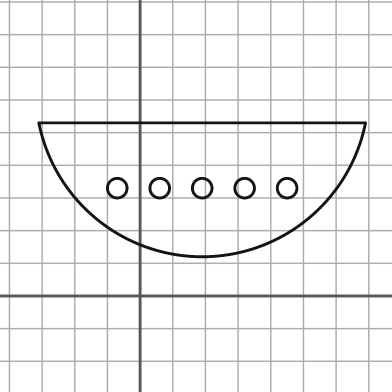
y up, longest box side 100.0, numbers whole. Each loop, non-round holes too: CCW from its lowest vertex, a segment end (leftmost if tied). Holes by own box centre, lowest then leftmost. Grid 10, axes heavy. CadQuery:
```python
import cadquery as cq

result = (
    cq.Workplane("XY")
    .moveTo(-31.0, 53.0)
    .threePointArc((19.0, 12.0), (69.0, 53.0))
    .close()
    .moveTo(-7.0, 33.0)
    .circle(3.0)
    .moveTo(6.0, 33.0)
    .circle(3.0)
    .moveTo(19.0, 33.0)
    .circle(3.0)
    .moveTo(32.0, 33.0)
    .circle(3.0)
    .moveTo(45.0, 33.0)
    .circle(3.0)
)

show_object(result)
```